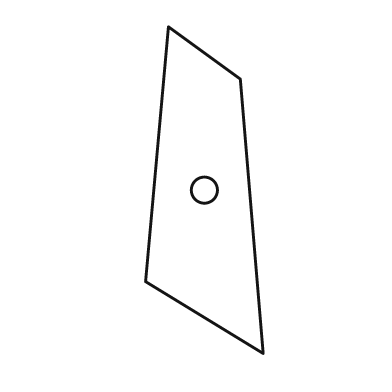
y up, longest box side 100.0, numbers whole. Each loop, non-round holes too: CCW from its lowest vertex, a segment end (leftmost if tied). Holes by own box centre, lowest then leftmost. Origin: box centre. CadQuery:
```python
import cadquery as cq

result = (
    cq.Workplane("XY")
    .moveTo(18.0, -50.0)
    .lineTo(11.0, 34.0)
    .lineTo(-11.0, 50.0)
    .lineTo(-18.0, -28.0)
    .close()
    .moveTo(0.0, 0.0)
    .circle(4.0)
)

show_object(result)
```